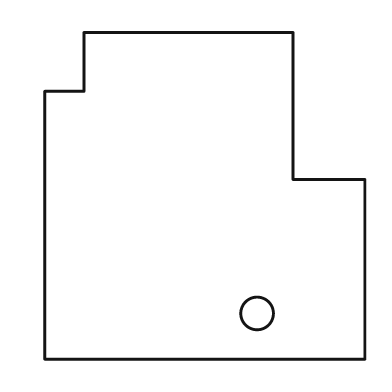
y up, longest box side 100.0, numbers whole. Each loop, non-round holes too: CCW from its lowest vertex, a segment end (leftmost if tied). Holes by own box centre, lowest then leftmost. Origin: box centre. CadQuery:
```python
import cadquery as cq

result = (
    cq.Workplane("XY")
    .moveTo(-49.0, -50.0)
    .lineTo(49.0, -50.0)
    .lineTo(49.0, 5.0)
    .lineTo(27.0, 5.0)
    .lineTo(27.0, 50.0)
    .lineTo(-37.0, 50.0)
    .lineTo(-37.0, 32.0)
    .lineTo(-49.0, 32.0)
    .close()
    .moveTo(16.0, -36.0)
    .circle(5.0)
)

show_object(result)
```